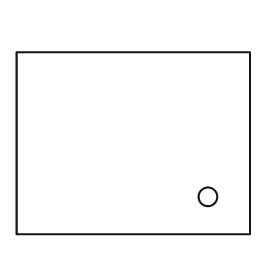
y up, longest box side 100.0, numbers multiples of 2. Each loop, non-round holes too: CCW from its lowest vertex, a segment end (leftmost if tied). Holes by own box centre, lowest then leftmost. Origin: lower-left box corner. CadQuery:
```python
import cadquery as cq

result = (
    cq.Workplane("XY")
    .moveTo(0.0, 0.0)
    .lineTo(100.0, 0.0)
    .lineTo(100.0, 78.0)
    .lineTo(0.0, 78.0)
    .close()
    .moveTo(82.0, 16.0)
    .circle(4.0)
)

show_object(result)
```